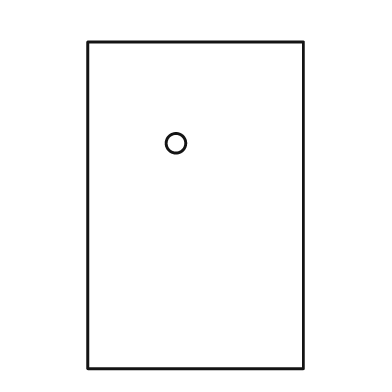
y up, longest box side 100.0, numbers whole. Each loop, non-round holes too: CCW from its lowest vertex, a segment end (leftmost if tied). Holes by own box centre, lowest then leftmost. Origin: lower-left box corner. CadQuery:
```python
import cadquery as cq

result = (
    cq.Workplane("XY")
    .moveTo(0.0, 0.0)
    .lineTo(66.0, 0.0)
    .lineTo(66.0, 100.0)
    .lineTo(0.0, 100.0)
    .close()
    .moveTo(27.0, 69.0)
    .circle(3.0)
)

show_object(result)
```